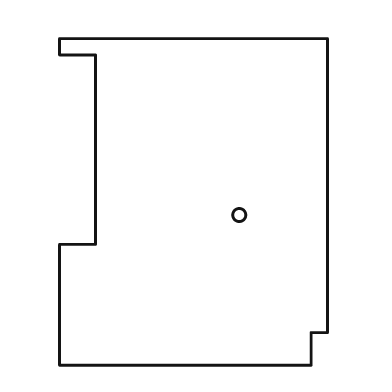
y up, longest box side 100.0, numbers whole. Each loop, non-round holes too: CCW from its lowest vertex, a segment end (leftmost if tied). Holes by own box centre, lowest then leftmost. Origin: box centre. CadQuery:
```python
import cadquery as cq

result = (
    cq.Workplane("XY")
    .moveTo(-41.0, -50.0)
    .lineTo(36.0, -50.0)
    .lineTo(36.0, -40.0)
    .lineTo(41.0, -40.0)
    .lineTo(41.0, 50.0)
    .lineTo(-41.0, 50.0)
    .lineTo(-41.0, 45.0)
    .lineTo(-30.0, 45.0)
    .lineTo(-30.0, -13.0)
    .lineTo(-41.0, -13.0)
    .close()
    .moveTo(14.0, -4.0)
    .circle(2.0)
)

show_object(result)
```